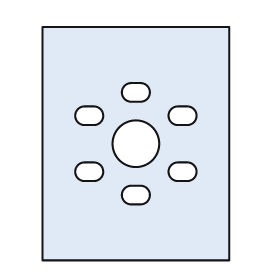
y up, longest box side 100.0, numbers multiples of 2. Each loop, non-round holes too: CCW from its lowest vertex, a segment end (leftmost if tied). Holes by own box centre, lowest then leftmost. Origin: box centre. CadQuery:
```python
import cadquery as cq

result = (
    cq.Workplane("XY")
    .moveTo(-40.0, -50.0)
    .lineTo(40.0, -50.0)
    .lineTo(40.0, 50.0)
    .lineTo(-40.0, 50.0)
    .close()
    .moveTo(-2.0, -26.0)
    .lineTo(2.0, -26.0)
    .threePointArc((6.0, -22.0), (2.0, -18.0))
    .lineTo(-2.0, -18.0)
    .threePointArc((-6.0, -22.0), (-2.0, -26.0))
    .close()
    .moveTo(-22.0, -16.0)
    .lineTo(-18.0, -16.0)
    .threePointArc((-14.0, -12.0), (-18.0, -8.0))
    .lineTo(-22.0, -8.0)
    .threePointArc((-26.0, -12.0), (-22.0, -16.0))
    .close()
    .moveTo(18.0, -16.0)
    .lineTo(22.0, -16.0)
    .threePointArc((26.0, -12.0), (22.0, -8.0))
    .lineTo(18.0, -8.0)
    .threePointArc((14.0, -12.0), (18.0, -16.0))
    .close()
    .moveTo(0.0, 0.0)
    .circle(10.0)
    .moveTo(-22.0, 8.0)
    .lineTo(-18.0, 8.0)
    .threePointArc((-14.0, 12.0), (-18.0, 16.0))
    .lineTo(-22.0, 16.0)
    .threePointArc((-26.0, 12.0), (-22.0, 8.0))
    .close()
    .moveTo(18.0, 8.0)
    .lineTo(22.0, 8.0)
    .threePointArc((26.0, 12.0), (22.0, 16.0))
    .lineTo(18.0, 16.0)
    .threePointArc((14.0, 12.0), (18.0, 8.0))
    .close()
    .moveTo(-2.0, 18.0)
    .lineTo(2.0, 18.0)
    .threePointArc((6.0, 22.0), (2.0, 26.0))
    .lineTo(-2.0, 26.0)
    .threePointArc((-6.0, 22.0), (-2.0, 18.0))
    .close()
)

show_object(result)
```